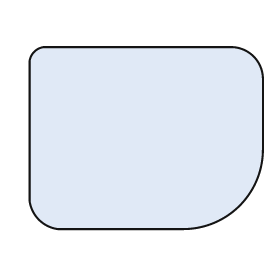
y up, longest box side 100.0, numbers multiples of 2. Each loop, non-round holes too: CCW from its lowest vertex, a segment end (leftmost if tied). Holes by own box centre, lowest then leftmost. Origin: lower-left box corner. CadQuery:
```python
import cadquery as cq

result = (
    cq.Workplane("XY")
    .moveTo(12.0, 0.0)
    .lineTo(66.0, 0.0)
    .threePointArc((90.0, 10.0), (100.0, 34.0))
    .lineTo(100.0, 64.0)
    .threePointArc((96.0, 74.0), (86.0, 78.0))
    .lineTo(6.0, 78.0)
    .threePointArc((2.0, 76.0), (0.0, 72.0))
    .lineTo(0.0, 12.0)
    .threePointArc((4.0, 4.0), (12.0, 0.0))
    .close()
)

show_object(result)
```